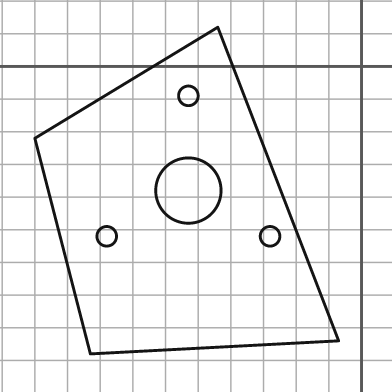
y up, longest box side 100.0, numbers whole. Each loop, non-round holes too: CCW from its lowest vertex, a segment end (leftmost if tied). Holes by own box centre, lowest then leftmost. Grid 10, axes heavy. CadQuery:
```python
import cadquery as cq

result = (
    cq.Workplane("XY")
    .moveTo(-83.0, -88.0)
    .lineTo(-7.0, -84.0)
    .lineTo(-44.0, 12.0)
    .lineTo(-100.0, -22.0)
    .close()
    .moveTo(-78.0, -52.0)
    .circle(3.0)
    .moveTo(-28.0, -52.0)
    .circle(3.0)
    .moveTo(-53.0, -38.0)
    .circle(10.0)
    .moveTo(-53.0, -9.0)
    .circle(3.0)
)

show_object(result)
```